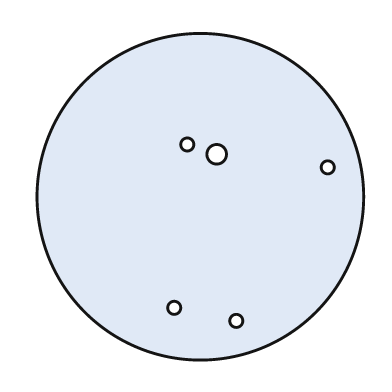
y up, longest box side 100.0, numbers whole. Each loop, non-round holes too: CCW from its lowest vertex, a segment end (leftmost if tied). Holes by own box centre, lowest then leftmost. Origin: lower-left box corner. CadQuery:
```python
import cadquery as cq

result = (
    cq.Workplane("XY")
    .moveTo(50.0, 50.0)
    .circle(50.0)
    .moveTo(61.0, 12.0)
    .circle(2.0)
    .moveTo(42.0, 16.0)
    .circle(2.0)
    .moveTo(89.0, 59.0)
    .circle(2.0)
    .moveTo(55.0, 63.0)
    .circle(3.0)
    .moveTo(46.0, 66.0)
    .circle(2.0)
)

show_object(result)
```